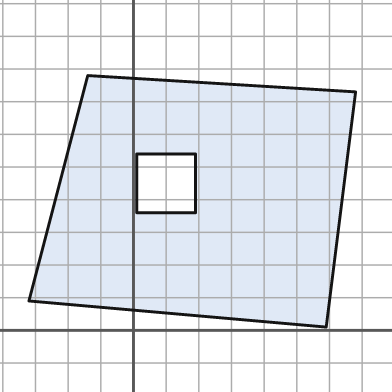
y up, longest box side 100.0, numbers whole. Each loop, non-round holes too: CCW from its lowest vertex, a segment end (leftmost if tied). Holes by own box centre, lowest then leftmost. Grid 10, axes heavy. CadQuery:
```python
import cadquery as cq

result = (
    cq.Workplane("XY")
    .moveTo(59.0, 1.0)
    .lineTo(68.0, 73.0)
    .lineTo(-14.0, 78.0)
    .lineTo(-32.0, 9.0)
    .close()
    .moveTo(1.0, 36.0)
    .lineTo(19.0, 36.0)
    .lineTo(19.0, 54.0)
    .lineTo(1.0, 54.0)
    .close()
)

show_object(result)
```